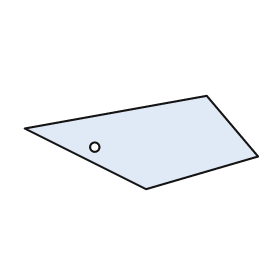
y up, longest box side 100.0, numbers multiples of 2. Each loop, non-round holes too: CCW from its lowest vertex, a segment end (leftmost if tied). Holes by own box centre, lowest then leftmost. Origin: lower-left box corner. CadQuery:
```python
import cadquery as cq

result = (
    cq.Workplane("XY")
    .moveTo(52.0, 0.0)
    .lineTo(100.0, 14.0)
    .lineTo(78.0, 40.0)
    .lineTo(0.0, 26.0)
    .close()
    .moveTo(30.0, 18.0)
    .circle(2.0)
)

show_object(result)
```